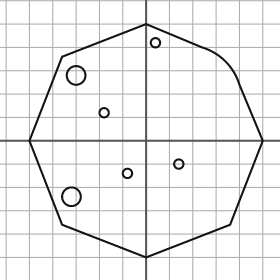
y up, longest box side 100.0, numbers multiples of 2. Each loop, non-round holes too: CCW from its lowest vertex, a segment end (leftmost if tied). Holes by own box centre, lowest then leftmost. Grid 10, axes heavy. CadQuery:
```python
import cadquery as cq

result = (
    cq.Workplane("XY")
    .moveTo(0.0, -50.0)
    .lineTo(36.0, -36.0)
    .lineTo(50.0, 0.0)
    .lineTo(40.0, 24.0)
    .threePointArc((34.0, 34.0), (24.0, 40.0))
    .lineTo(0.0, 50.0)
    .lineTo(-36.0, 36.0)
    .lineTo(-50.0, 0.0)
    .lineTo(-36.0, -36.0)
    .close()
    .moveTo(-32.0, -24.0)
    .circle(4.0)
    .moveTo(-8.0, -14.0)
    .circle(2.0)
    .moveTo(14.0, -10.0)
    .circle(2.0)
    .moveTo(-18.0, 12.0)
    .circle(2.0)
    .moveTo(-30.0, 28.0)
    .circle(4.0)
    .moveTo(4.0, 42.0)
    .circle(2.0)
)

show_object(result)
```